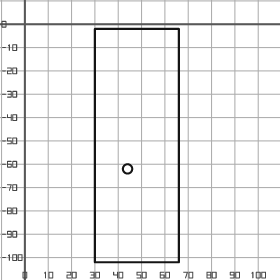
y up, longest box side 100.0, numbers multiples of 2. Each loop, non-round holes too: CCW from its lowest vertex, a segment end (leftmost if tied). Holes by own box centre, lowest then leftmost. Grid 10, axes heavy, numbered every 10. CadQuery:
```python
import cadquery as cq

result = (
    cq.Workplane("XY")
    .moveTo(30.0, -102.0)
    .lineTo(66.0, -102.0)
    .lineTo(66.0, -2.0)
    .lineTo(30.0, -2.0)
    .close()
    .moveTo(44.0, -62.0)
    .circle(2.0)
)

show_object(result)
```